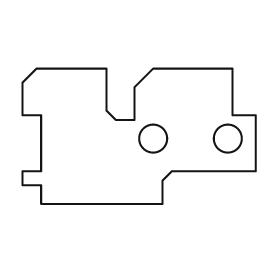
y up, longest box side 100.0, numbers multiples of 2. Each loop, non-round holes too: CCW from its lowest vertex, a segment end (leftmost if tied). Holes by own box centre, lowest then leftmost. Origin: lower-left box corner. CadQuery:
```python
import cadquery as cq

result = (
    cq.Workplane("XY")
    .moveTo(8.0, 0.0)
    .lineTo(60.0, 0.0)
    .lineTo(60.0, 10.0)
    .lineTo(64.0, 14.0)
    .lineTo(100.0, 14.0)
    .lineTo(100.0, 38.0)
    .lineTo(90.0, 38.0)
    .lineTo(90.0, 58.0)
    .lineTo(56.0, 58.0)
    .lineTo(48.0, 50.0)
    .lineTo(48.0, 36.0)
    .lineTo(40.0, 36.0)
    .lineTo(36.0, 40.0)
    .lineTo(36.0, 58.0)
    .lineTo(6.0, 58.0)
    .lineTo(0.0, 52.0)
    .lineTo(0.0, 38.0)
    .lineTo(8.0, 38.0)
    .lineTo(8.0, 14.0)
    .lineTo(0.0, 14.0)
    .lineTo(0.0, 8.0)
    .lineTo(8.0, 8.0)
    .close()
    .moveTo(56.0, 28.0)
    .circle(6.0)
    .moveTo(88.0, 28.0)
    .circle(6.0)
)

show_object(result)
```